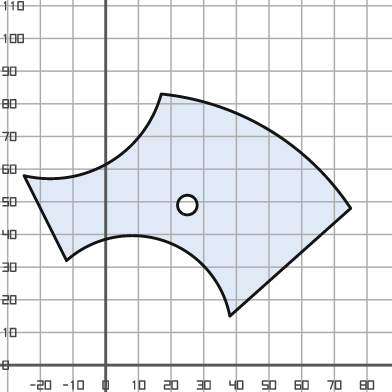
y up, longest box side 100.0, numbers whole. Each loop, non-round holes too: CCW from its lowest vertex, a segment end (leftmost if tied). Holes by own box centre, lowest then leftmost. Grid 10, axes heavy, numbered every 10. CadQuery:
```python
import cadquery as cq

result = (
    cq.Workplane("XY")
    .moveTo(38.0, 15.0)
    .lineTo(75.0, 48.0)
    .threePointArc((50.0, 72.0), (17.0, 83.0))
    .threePointArc((1.0, 62.0), (-25.0, 58.0))
    .lineTo(-12.0, 32.0)
    .threePointArc((18.0, 38.0), (38.0, 15.0))
    .close()
    .moveTo(25.0, 49.0)
    .circle(3.0)
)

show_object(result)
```